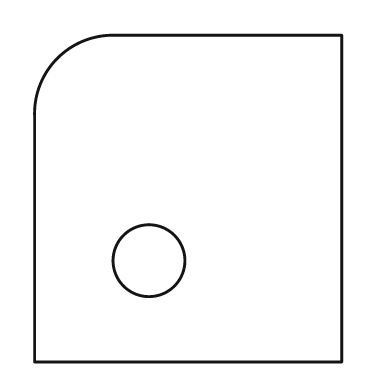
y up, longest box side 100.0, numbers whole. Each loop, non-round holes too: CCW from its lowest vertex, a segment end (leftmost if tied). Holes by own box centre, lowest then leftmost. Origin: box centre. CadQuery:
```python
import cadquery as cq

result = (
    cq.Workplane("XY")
    .moveTo(-47.0, -50.0)
    .lineTo(47.0, -50.0)
    .lineTo(47.0, 50.0)
    .lineTo(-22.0, 50.0)
    .threePointArc((-40.0, 43.0), (-47.0, 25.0))
    .close()
    .moveTo(-12.0, -19.0)
    .circle(11.0)
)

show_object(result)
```